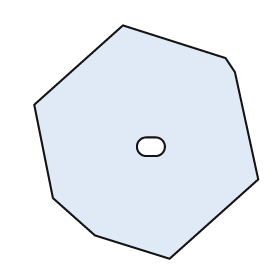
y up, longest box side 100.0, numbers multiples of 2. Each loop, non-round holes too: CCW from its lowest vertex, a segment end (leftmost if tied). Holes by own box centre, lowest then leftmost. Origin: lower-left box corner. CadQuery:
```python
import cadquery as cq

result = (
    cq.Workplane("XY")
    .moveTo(58.0, 0.0)
    .lineTo(96.0, 34.0)
    .lineTo(86.0, 80.0)
    .lineTo(82.0, 86.0)
    .lineTo(38.0, 100.0)
    .lineTo(0.0, 66.0)
    .lineTo(8.0, 26.0)
    .lineTo(26.0, 10.0)
    .close()
    .moveTo(48.0, 44.0)
    .lineTo(52.0, 44.0)
    .threePointArc((56.0, 48.0), (52.0, 52.0))
    .lineTo(48.0, 52.0)
    .threePointArc((44.0, 48.0), (48.0, 44.0))
    .close()
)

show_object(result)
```